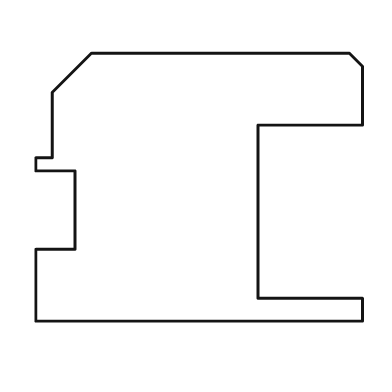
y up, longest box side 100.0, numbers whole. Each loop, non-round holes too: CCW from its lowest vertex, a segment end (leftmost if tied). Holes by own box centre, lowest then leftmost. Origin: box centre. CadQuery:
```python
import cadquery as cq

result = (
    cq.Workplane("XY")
    .moveTo(-50.0, -41.0)
    .lineTo(50.0, -41.0)
    .lineTo(50.0, -34.0)
    .lineTo(18.0, -34.0)
    .lineTo(18.0, 19.0)
    .lineTo(50.0, 19.0)
    .lineTo(50.0, 37.0)
    .lineTo(46.0, 41.0)
    .lineTo(-33.0, 41.0)
    .lineTo(-45.0, 29.0)
    .lineTo(-45.0, 9.0)
    .lineTo(-50.0, 9.0)
    .lineTo(-50.0, 5.0)
    .lineTo(-38.0, 5.0)
    .lineTo(-38.0, -19.0)
    .lineTo(-50.0, -19.0)
    .close()
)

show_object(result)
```